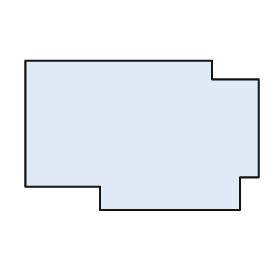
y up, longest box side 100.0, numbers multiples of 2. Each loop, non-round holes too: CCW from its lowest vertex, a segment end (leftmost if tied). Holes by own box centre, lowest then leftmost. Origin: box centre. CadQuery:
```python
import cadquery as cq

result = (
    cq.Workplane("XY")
    .moveTo(-18.0, -32.0)
    .lineTo(42.0, -32.0)
    .lineTo(42.0, -18.0)
    .lineTo(50.0, -18.0)
    .lineTo(50.0, 24.0)
    .lineTo(30.0, 24.0)
    .lineTo(30.0, 32.0)
    .lineTo(-50.0, 32.0)
    .lineTo(-50.0, -22.0)
    .lineTo(-18.0, -22.0)
    .close()
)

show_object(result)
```